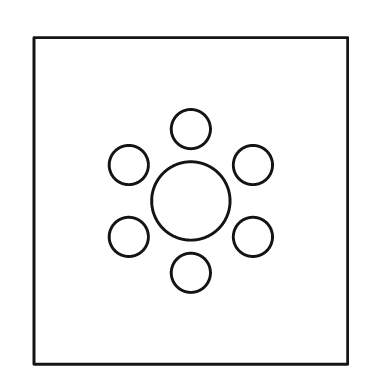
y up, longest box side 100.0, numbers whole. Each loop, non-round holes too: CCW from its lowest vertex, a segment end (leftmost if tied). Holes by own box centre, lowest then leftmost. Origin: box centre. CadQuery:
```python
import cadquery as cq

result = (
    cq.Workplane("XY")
    .moveTo(-48.0, -50.0)
    .lineTo(48.0, -50.0)
    .lineTo(48.0, 50.0)
    .lineTo(-48.0, 50.0)
    .close()
    .moveTo(0.0, -22.0)
    .circle(6.0)
    .moveTo(-19.0, -11.0)
    .circle(6.0)
    .moveTo(19.0, -11.0)
    .circle(6.0)
    .moveTo(0.0, 0.0)
    .circle(12.0)
    .moveTo(-19.0, 11.0)
    .circle(6.0)
    .moveTo(19.0, 11.0)
    .circle(6.0)
    .moveTo(0.0, 22.0)
    .circle(6.0)
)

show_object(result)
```